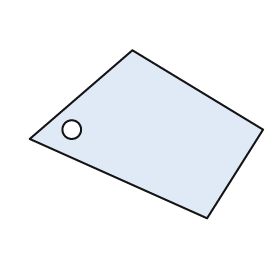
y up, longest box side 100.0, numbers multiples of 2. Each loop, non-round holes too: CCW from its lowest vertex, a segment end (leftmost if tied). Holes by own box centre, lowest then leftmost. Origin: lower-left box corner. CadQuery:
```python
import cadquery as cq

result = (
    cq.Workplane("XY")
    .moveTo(76.0, 0.0)
    .lineTo(100.0, 38.0)
    .lineTo(44.0, 72.0)
    .lineTo(0.0, 34.0)
    .close()
    .moveTo(18.0, 38.0)
    .circle(4.0)
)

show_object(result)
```